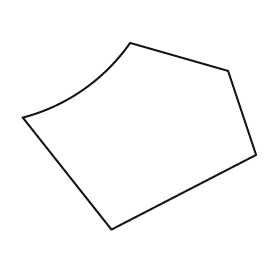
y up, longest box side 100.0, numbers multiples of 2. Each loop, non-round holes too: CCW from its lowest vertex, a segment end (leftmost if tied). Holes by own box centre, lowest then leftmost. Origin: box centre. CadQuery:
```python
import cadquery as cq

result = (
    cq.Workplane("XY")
    .moveTo(-12.0, -40.0)
    .lineTo(50.0, -8.0)
    .lineTo(38.0, 28.0)
    .lineTo(-4.0, 40.0)
    .threePointArc((-24.0, 20.0), (-50.0, 8.0))
    .close()
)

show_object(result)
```